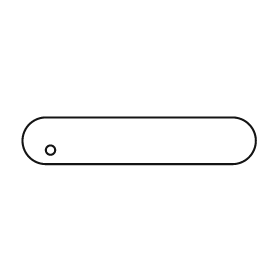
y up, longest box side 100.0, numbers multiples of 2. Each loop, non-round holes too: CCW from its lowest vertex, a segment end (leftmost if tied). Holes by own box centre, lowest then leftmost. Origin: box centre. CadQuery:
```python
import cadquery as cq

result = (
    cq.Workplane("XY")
    .moveTo(-40.0, -10.0)
    .lineTo(40.0, -10.0)
    .threePointArc((50.0, 0.0), (40.0, 10.0))
    .lineTo(-40.0, 10.0)
    .threePointArc((-50.0, 0.0), (-40.0, -10.0))
    .close()
    .moveTo(-38.0, -4.0)
    .circle(2.0)
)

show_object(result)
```